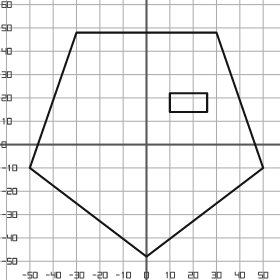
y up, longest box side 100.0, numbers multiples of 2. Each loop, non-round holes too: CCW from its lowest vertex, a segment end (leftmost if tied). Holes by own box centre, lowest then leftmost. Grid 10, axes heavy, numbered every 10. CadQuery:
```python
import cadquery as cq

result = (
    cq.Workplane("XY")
    .moveTo(0.0, -48.0)
    .lineTo(50.0, -10.0)
    .lineTo(30.0, 48.0)
    .lineTo(-30.0, 48.0)
    .lineTo(-50.0, -10.0)
    .close()
    .moveTo(10.0, 14.0)
    .lineTo(26.0, 14.0)
    .lineTo(26.0, 22.0)
    .lineTo(10.0, 22.0)
    .close()
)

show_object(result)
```